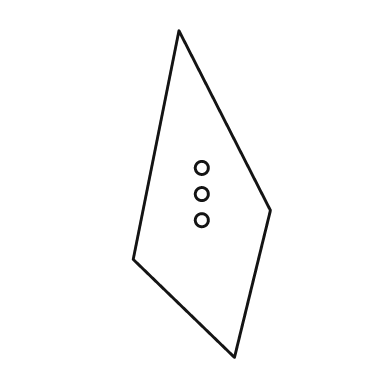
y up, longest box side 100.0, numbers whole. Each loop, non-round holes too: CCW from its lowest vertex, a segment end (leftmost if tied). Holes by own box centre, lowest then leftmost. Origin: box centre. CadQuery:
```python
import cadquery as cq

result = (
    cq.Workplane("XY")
    .moveTo(10.0, -50.0)
    .lineTo(21.0, -5.0)
    .lineTo(-7.0, 50.0)
    .lineTo(-21.0, -20.0)
    .close()
    .moveTo(0.0, -8.0)
    .circle(2.0)
    .moveTo(0.0, 0.0)
    .circle(2.0)
    .moveTo(0.0, 8.0)
    .circle(2.0)
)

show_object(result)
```